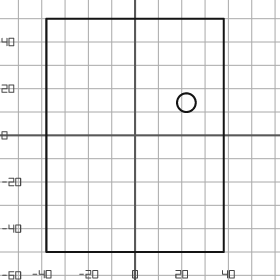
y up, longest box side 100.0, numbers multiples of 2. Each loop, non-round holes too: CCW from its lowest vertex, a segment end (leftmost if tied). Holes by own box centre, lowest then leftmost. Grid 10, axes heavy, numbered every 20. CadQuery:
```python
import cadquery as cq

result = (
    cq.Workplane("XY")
    .moveTo(-38.0, -50.0)
    .lineTo(38.0, -50.0)
    .lineTo(38.0, 50.0)
    .lineTo(-38.0, 50.0)
    .close()
    .moveTo(22.0, 14.0)
    .circle(4.0)
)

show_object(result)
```